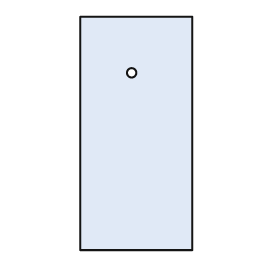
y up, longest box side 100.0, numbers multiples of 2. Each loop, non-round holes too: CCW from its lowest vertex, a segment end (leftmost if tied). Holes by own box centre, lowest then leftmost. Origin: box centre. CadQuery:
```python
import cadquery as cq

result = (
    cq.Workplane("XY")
    .moveTo(-24.0, -50.0)
    .lineTo(24.0, -50.0)
    .lineTo(24.0, 50.0)
    .lineTo(-24.0, 50.0)
    .close()
    .moveTo(-2.0, 26.0)
    .circle(2.0)
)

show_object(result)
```